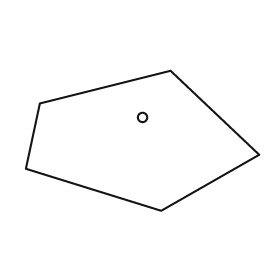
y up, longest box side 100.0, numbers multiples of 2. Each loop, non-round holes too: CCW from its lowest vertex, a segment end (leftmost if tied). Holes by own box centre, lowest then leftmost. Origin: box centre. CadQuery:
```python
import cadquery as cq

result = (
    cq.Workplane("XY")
    .moveTo(8.0, -30.0)
    .lineTo(50.0, -6.0)
    .lineTo(12.0, 30.0)
    .lineTo(-44.0, 16.0)
    .lineTo(-50.0, -12.0)
    .close()
    .moveTo(0.0, 10.0)
    .circle(2.0)
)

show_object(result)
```